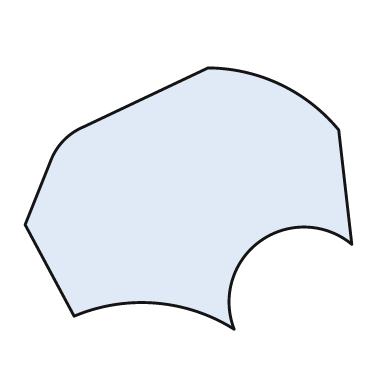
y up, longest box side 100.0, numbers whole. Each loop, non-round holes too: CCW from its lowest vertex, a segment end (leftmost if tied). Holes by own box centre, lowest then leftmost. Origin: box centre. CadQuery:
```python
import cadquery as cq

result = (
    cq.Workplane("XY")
    .moveTo(14.0, -40.0)
    .threePointArc((22.0, -13.0), (50.0, -14.0))
    .lineTo(46.0, 21.0)
    .threePointArc((28.0, 35.0), (6.0, 40.0))
    .lineTo(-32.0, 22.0)
    .threePointArc((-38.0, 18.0), (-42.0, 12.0))
    .lineTo(-50.0, -8.0)
    .lineTo(-35.0, -36.0)
    .threePointArc((-10.0, -32.0), (14.0, -40.0))
    .close()
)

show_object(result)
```